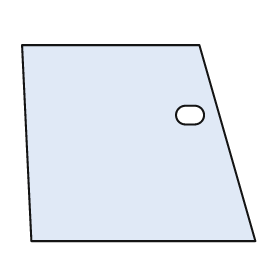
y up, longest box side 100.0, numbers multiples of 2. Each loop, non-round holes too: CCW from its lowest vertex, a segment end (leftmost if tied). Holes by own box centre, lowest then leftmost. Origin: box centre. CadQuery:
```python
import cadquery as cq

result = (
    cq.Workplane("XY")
    .moveTo(-46.0, -42.0)
    .lineTo(50.0, -42.0)
    .lineTo(26.0, 42.0)
    .lineTo(-50.0, 42.0)
    .close()
    .moveTo(20.0, 8.0)
    .lineTo(24.0, 8.0)
    .threePointArc((28.0, 12.0), (24.0, 16.0))
    .lineTo(20.0, 16.0)
    .threePointArc((16.0, 12.0), (20.0, 8.0))
    .close()
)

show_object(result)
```